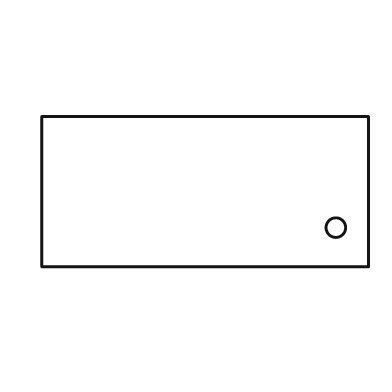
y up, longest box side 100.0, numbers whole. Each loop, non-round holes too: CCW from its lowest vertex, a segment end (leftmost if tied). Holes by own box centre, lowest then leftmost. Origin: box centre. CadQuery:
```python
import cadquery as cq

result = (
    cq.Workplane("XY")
    .moveTo(-50.0, -23.0)
    .lineTo(50.0, -23.0)
    .lineTo(50.0, 23.0)
    .lineTo(-50.0, 23.0)
    .close()
    .moveTo(40.0, -11.0)
    .circle(3.0)
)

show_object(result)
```